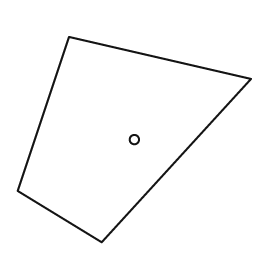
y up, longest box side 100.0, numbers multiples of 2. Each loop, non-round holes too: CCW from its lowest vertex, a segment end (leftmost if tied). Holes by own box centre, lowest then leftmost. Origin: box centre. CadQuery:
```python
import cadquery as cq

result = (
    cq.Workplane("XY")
    .moveTo(-14.0, -44.0)
    .lineTo(50.0, 26.0)
    .lineTo(-28.0, 44.0)
    .lineTo(-50.0, -22.0)
    .close()
    .moveTo(0.0, 0.0)
    .circle(2.0)
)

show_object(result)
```